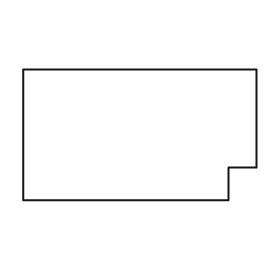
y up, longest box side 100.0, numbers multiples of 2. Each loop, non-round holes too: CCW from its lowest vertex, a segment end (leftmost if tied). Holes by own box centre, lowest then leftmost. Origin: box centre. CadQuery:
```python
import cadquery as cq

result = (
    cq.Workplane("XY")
    .moveTo(-50.0, -28.0)
    .lineTo(38.0, -28.0)
    .lineTo(38.0, -14.0)
    .lineTo(50.0, -14.0)
    .lineTo(50.0, 28.0)
    .lineTo(-50.0, 28.0)
    .close()
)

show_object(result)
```